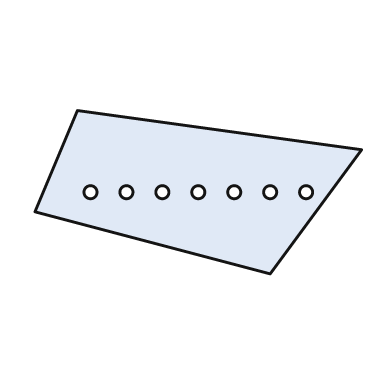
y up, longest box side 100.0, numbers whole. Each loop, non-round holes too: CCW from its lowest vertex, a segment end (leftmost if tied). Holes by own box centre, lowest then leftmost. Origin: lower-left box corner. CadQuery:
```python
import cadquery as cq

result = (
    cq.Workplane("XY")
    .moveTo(72.0, 0.0)
    .lineTo(100.0, 38.0)
    .lineTo(13.0, 50.0)
    .lineTo(0.0, 19.0)
    .close()
    .moveTo(17.0, 25.0)
    .circle(2.0)
    .moveTo(28.0, 25.0)
    .circle(2.0)
    .moveTo(39.0, 25.0)
    .circle(2.0)
    .moveTo(50.0, 25.0)
    .circle(2.0)
    .moveTo(61.0, 25.0)
    .circle(2.0)
    .moveTo(72.0, 25.0)
    .circle(2.0)
    .moveTo(83.0, 25.0)
    .circle(2.0)
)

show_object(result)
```